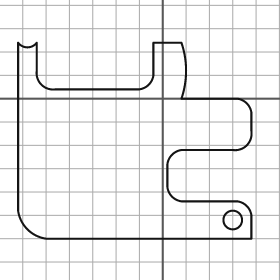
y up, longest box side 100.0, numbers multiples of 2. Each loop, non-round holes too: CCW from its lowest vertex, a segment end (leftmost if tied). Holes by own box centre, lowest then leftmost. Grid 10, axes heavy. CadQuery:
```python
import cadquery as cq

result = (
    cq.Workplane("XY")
    .moveTo(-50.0, -60.0)
    .lineTo(38.0, -60.0)
    .lineTo(38.0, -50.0)
    .threePointArc((36.0, -46.0), (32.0, -44.0))
    .lineTo(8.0, -44.0)
    .threePointArc((4.0, -42.0), (2.0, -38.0))
    .lineTo(2.0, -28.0)
    .threePointArc((4.0, -24.0), (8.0, -22.0))
    .lineTo(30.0, -22.0)
    .threePointArc((36.0, -20.0), (38.0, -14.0))
    .lineTo(38.0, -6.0)
    .threePointArc((36.0, -2.0), (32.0, 0.0))
    .lineTo(8.0, 0.0)
    .threePointArc((10.0, 12.0), (8.0, 24.0))
    .lineTo(-4.0, 24.0)
    .lineTo(-4.0, 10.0)
    .threePointArc((-6.0, 6.0), (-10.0, 4.0))
    .lineTo(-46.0, 4.0)
    .threePointArc((-52.0, 6.0), (-54.0, 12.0))
    .lineTo(-54.0, 24.0)
    .threePointArc((-58.0, 22.0), (-62.0, 24.0))
    .lineTo(-62.0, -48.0)
    .threePointArc((-58.0, -56.0), (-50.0, -60.0))
    .close()
    .moveTo(30.0, -52.0)
    .circle(4.0)
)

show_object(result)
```